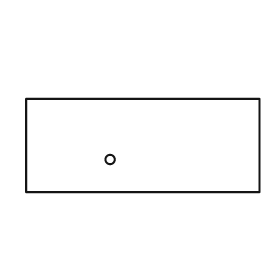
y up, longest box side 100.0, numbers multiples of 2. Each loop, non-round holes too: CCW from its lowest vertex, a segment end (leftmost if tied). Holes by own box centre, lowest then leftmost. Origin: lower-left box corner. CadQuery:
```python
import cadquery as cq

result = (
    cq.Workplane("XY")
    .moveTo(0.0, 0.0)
    .lineTo(100.0, 0.0)
    .lineTo(100.0, 40.0)
    .lineTo(0.0, 40.0)
    .close()
    .moveTo(36.0, 14.0)
    .circle(2.0)
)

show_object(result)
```